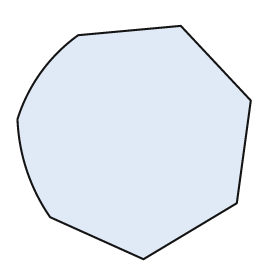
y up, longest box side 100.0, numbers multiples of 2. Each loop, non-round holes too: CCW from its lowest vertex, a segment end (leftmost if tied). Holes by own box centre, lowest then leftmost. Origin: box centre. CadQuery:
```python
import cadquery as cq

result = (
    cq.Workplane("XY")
    .moveTo(4.0, -50.0)
    .lineTo(44.0, -26.0)
    .lineTo(50.0, 18.0)
    .lineTo(20.0, 50.0)
    .lineTo(-24.0, 46.0)
    .threePointArc((-40.0, 30.0), (-50.0, 10.0))
    .threePointArc((-46.0, -12.0), (-36.0, -32.0))
    .close()
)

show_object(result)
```